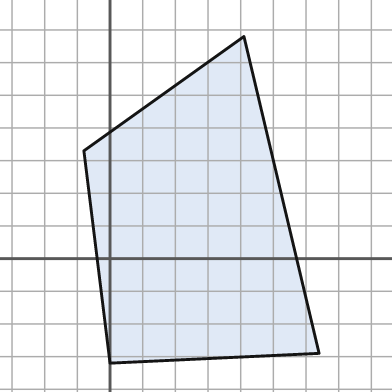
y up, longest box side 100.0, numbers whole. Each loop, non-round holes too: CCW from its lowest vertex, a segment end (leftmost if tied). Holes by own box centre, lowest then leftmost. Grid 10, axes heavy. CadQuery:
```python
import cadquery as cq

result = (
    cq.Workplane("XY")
    .moveTo(0.0, -32.0)
    .lineTo(64.0, -29.0)
    .lineTo(41.0, 68.0)
    .lineTo(-8.0, 33.0)
    .close()
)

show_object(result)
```